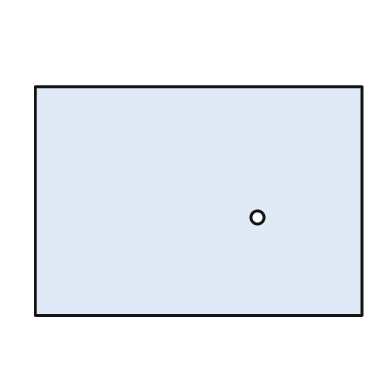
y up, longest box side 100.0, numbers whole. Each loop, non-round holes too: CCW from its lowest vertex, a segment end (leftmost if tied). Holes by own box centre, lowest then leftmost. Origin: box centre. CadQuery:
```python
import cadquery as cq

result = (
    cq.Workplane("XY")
    .moveTo(-50.0, -35.0)
    .lineTo(50.0, -35.0)
    .lineTo(50.0, 35.0)
    .lineTo(-50.0, 35.0)
    .close()
    .moveTo(18.0, -5.0)
    .circle(2.0)
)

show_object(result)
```